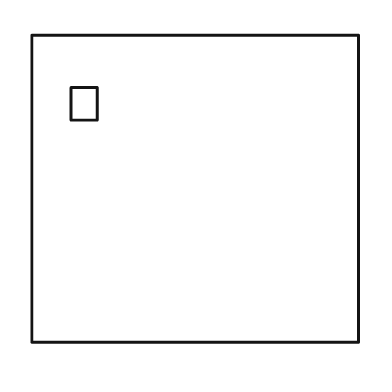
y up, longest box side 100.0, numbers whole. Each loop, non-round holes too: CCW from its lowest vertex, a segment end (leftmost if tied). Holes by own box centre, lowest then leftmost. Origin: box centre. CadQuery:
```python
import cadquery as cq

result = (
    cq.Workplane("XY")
    .moveTo(-50.0, -47.0)
    .lineTo(50.0, -47.0)
    .lineTo(50.0, 47.0)
    .lineTo(-50.0, 47.0)
    .close()
    .moveTo(-38.0, 21.0)
    .lineTo(-30.0, 21.0)
    .lineTo(-30.0, 31.0)
    .lineTo(-38.0, 31.0)
    .close()
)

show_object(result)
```